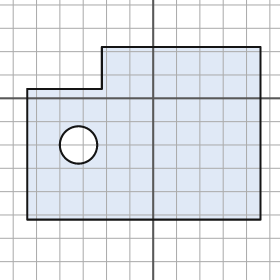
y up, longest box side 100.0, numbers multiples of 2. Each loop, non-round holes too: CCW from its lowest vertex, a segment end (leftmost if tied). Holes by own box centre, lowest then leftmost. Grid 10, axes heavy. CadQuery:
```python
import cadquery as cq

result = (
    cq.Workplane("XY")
    .moveTo(-54.0, -52.0)
    .lineTo(46.0, -52.0)
    .lineTo(46.0, 22.0)
    .lineTo(-22.0, 22.0)
    .lineTo(-22.0, 4.0)
    .lineTo(-54.0, 4.0)
    .close()
    .moveTo(-32.0, -20.0)
    .circle(8.0)
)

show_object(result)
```